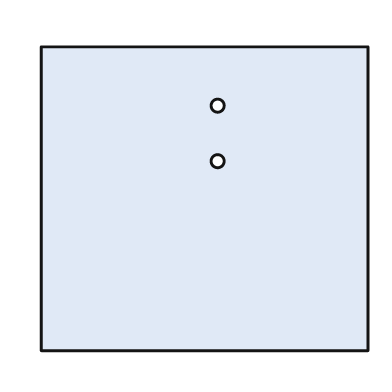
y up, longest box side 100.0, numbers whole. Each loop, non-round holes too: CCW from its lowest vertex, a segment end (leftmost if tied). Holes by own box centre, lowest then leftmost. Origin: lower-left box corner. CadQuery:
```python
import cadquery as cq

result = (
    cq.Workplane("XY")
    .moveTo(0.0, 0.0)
    .lineTo(100.0, 0.0)
    .lineTo(100.0, 93.0)
    .lineTo(0.0, 93.0)
    .close()
    .moveTo(54.0, 58.0)
    .circle(2.0)
    .moveTo(54.0, 75.0)
    .circle(2.0)
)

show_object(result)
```